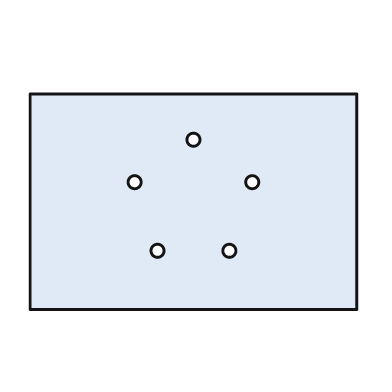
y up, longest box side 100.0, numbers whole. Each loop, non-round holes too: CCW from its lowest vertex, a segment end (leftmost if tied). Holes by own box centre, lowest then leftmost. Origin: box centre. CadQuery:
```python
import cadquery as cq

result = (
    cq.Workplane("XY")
    .moveTo(-50.0, -33.0)
    .lineTo(50.0, -33.0)
    .lineTo(50.0, 33.0)
    .lineTo(-50.0, 33.0)
    .close()
    .moveTo(-11.0, -15.0)
    .circle(2.0)
    .moveTo(11.0, -15.0)
    .circle(2.0)
    .moveTo(-18.0, 6.0)
    .circle(2.0)
    .moveTo(18.0, 6.0)
    .circle(2.0)
    .moveTo(0.0, 19.0)
    .circle(2.0)
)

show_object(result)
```